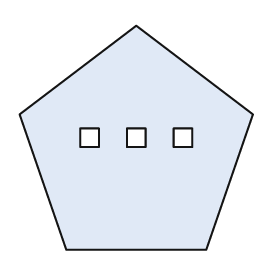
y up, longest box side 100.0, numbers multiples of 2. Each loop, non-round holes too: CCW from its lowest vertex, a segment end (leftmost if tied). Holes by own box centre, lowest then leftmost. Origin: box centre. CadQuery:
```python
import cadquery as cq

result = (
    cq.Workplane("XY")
    .moveTo(-30.0, -48.0)
    .lineTo(30.0, -48.0)
    .lineTo(50.0, 10.0)
    .lineTo(0.0, 48.0)
    .lineTo(-50.0, 10.0)
    .close()
    .moveTo(-24.0, -4.0)
    .lineTo(-16.0, -4.0)
    .lineTo(-16.0, 4.0)
    .lineTo(-24.0, 4.0)
    .close()
    .moveTo(-4.0, -4.0)
    .lineTo(4.0, -4.0)
    .lineTo(4.0, 4.0)
    .lineTo(-4.0, 4.0)
    .close()
    .moveTo(16.0, -4.0)
    .lineTo(24.0, -4.0)
    .lineTo(24.0, 4.0)
    .lineTo(16.0, 4.0)
    .close()
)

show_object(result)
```